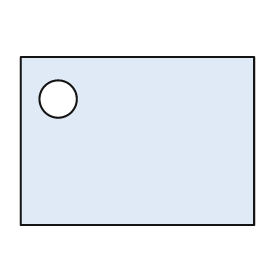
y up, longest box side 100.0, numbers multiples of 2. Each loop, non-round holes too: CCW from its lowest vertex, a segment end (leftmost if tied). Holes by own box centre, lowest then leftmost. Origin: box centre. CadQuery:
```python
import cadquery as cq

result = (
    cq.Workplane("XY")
    .moveTo(-50.0, -36.0)
    .lineTo(50.0, -36.0)
    .lineTo(50.0, 36.0)
    .lineTo(-50.0, 36.0)
    .close()
    .moveTo(-34.0, 18.0)
    .circle(8.0)
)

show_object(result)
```